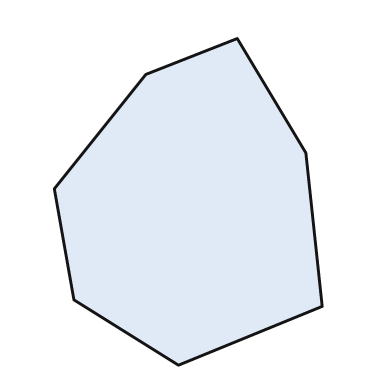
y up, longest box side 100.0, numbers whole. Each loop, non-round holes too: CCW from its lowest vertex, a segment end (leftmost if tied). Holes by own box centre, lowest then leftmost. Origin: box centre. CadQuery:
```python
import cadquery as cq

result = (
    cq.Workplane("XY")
    .moveTo(-3.0, -50.0)
    .lineTo(41.0, -32.0)
    .lineTo(36.0, 15.0)
    .lineTo(15.0, 50.0)
    .lineTo(-13.0, 39.0)
    .lineTo(-41.0, 4.0)
    .lineTo(-35.0, -30.0)
    .close()
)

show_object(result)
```